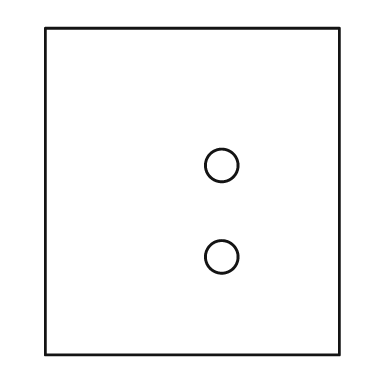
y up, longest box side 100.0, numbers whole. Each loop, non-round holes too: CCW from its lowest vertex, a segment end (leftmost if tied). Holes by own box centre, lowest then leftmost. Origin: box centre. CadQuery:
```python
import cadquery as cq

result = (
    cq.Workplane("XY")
    .moveTo(-45.0, -50.0)
    .lineTo(45.0, -50.0)
    .lineTo(45.0, 50.0)
    .lineTo(-45.0, 50.0)
    .close()
    .moveTo(9.0, -20.0)
    .circle(5.0)
    .moveTo(9.0, 8.0)
    .circle(5.0)
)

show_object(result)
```